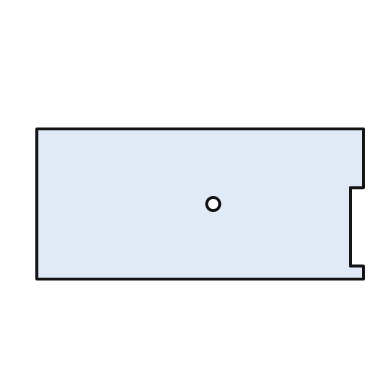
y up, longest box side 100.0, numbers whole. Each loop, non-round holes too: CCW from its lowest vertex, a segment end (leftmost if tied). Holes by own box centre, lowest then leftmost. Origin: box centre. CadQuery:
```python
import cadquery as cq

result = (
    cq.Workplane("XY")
    .moveTo(-50.0, -23.0)
    .lineTo(50.0, -23.0)
    .lineTo(50.0, -19.0)
    .lineTo(46.0, -19.0)
    .lineTo(46.0, 5.0)
    .lineTo(50.0, 5.0)
    .lineTo(50.0, 23.0)
    .lineTo(-50.0, 23.0)
    .close()
    .moveTo(4.0, 0.0)
    .circle(2.0)
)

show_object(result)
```